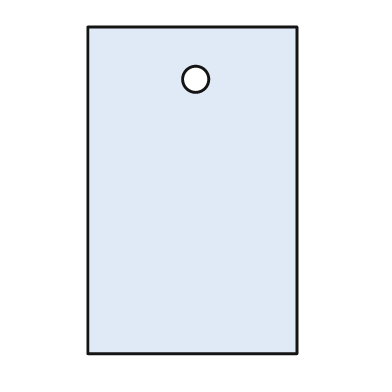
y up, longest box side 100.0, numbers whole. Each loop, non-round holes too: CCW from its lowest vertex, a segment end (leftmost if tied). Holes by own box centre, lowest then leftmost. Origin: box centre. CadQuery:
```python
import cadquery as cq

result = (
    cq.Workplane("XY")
    .moveTo(-32.0, -50.0)
    .lineTo(32.0, -50.0)
    .lineTo(32.0, 50.0)
    .lineTo(-32.0, 50.0)
    .close()
    .moveTo(1.0, 34.0)
    .circle(4.0)
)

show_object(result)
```